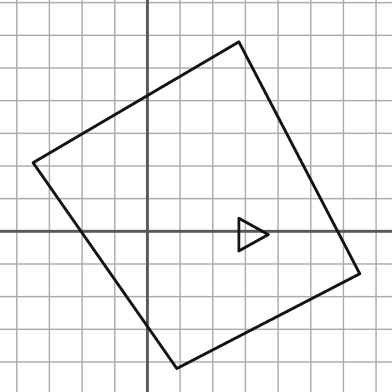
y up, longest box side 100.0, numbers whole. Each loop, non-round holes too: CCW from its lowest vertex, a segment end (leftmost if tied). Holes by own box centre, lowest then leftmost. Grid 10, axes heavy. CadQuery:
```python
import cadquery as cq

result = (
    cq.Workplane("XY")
    .moveTo(9.0, -42.0)
    .lineTo(65.0, -13.0)
    .lineTo(28.0, 58.0)
    .lineTo(-35.0, 21.0)
    .close()
    .moveTo(28.0, -6.0)
    .lineTo(37.0, -1.0)
    .lineTo(28.0, 4.0)
    .close()
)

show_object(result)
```